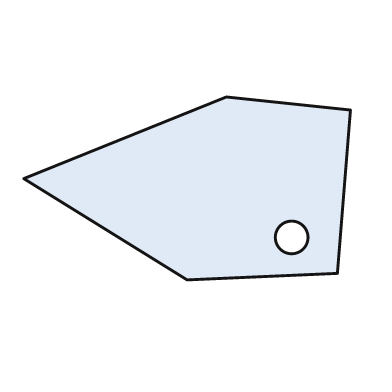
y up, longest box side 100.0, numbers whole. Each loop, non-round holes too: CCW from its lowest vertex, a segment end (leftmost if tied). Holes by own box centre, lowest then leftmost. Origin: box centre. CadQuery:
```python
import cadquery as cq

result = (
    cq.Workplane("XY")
    .moveTo(0.0, -28.0)
    .lineTo(46.0, -26.0)
    .lineTo(50.0, 24.0)
    .lineTo(12.0, 28.0)
    .lineTo(-50.0, 3.0)
    .close()
    .moveTo(32.0, -15.0)
    .circle(5.0)
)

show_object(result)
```